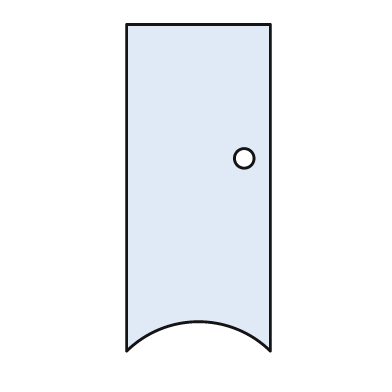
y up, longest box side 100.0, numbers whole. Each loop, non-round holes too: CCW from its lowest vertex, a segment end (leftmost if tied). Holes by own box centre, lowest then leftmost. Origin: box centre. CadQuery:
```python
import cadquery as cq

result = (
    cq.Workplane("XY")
    .moveTo(-22.0, -50.0)
    .threePointArc((0.0, -41.0), (22.0, -50.0))
    .lineTo(22.0, 50.0)
    .lineTo(-22.0, 50.0)
    .close()
    .moveTo(14.0, 9.0)
    .circle(3.0)
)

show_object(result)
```